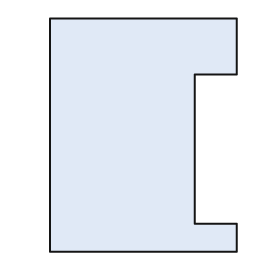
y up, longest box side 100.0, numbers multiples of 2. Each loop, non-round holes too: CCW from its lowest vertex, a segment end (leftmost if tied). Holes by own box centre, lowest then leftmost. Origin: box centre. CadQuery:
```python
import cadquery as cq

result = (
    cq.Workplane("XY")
    .moveTo(-40.0, -50.0)
    .lineTo(40.0, -50.0)
    .lineTo(40.0, -38.0)
    .lineTo(22.0, -38.0)
    .lineTo(22.0, 26.0)
    .lineTo(40.0, 26.0)
    .lineTo(40.0, 50.0)
    .lineTo(-40.0, 50.0)
    .close()
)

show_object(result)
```